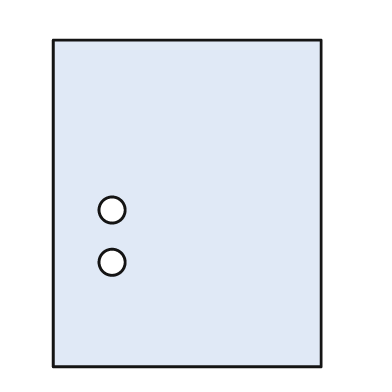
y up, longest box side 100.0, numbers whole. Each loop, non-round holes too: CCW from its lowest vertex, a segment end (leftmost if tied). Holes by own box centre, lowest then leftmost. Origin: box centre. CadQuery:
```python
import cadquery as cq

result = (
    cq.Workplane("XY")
    .moveTo(-41.0, -50.0)
    .lineTo(41.0, -50.0)
    .lineTo(41.0, 50.0)
    .lineTo(-41.0, 50.0)
    .close()
    .moveTo(-23.0, -18.0)
    .circle(4.0)
    .moveTo(-23.0, -2.0)
    .circle(4.0)
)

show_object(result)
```